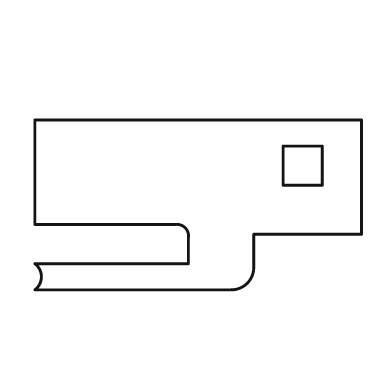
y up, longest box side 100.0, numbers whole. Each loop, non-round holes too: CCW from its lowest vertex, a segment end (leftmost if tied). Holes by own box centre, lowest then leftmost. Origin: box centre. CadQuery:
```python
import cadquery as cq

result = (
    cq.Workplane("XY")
    .moveTo(-50.0, -26.0)
    .lineTo(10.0, -26.0)
    .threePointArc((15.0, -24.0), (17.0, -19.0))
    .lineTo(17.0, -9.0)
    .lineTo(50.0, -9.0)
    .lineTo(50.0, 26.0)
    .lineTo(-50.0, 26.0)
    .lineTo(-50.0, -6.0)
    .lineTo(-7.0, -6.0)
    .threePointArc((-4.0, -7.0), (-3.0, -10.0))
    .lineTo(-3.0, -18.0)
    .lineTo(-50.0, -18.0)
    .threePointArc((-48.0, -22.0), (-50.0, -26.0))
    .close()
    .moveTo(26.0, 6.0)
    .lineTo(38.0, 6.0)
    .lineTo(38.0, 18.0)
    .lineTo(26.0, 18.0)
    .close()
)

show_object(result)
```